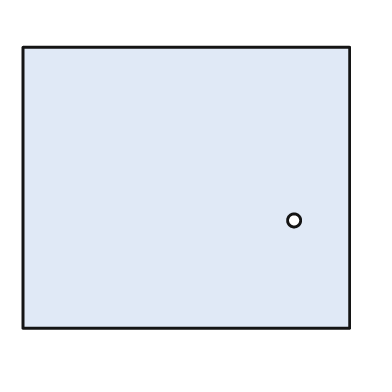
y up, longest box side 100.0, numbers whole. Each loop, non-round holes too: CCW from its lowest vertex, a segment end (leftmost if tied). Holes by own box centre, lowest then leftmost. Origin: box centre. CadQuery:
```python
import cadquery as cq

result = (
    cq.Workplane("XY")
    .moveTo(-50.0, -43.0)
    .lineTo(50.0, -43.0)
    .lineTo(50.0, 43.0)
    .lineTo(-50.0, 43.0)
    .close()
    .moveTo(33.0, -10.0)
    .circle(2.0)
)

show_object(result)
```